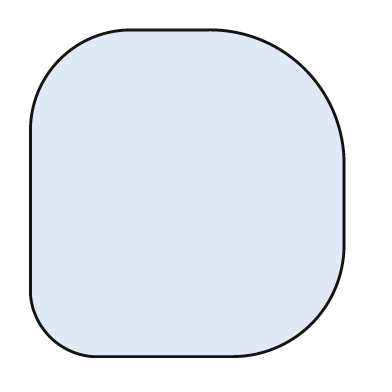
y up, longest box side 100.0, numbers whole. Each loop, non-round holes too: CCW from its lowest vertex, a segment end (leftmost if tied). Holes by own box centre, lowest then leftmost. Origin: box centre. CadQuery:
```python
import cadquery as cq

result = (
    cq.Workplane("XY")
    .moveTo(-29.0, -50.0)
    .lineTo(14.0, -50.0)
    .threePointArc((38.0, -40.0), (48.0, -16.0))
    .lineTo(48.0, 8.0)
    .threePointArc((36.0, 38.0), (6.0, 50.0))
    .lineTo(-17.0, 50.0)
    .threePointArc((-39.0, 41.0), (-48.0, 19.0))
    .lineTo(-48.0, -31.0)
    .threePointArc((-42.0, -44.0), (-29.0, -50.0))
    .close()
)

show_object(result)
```